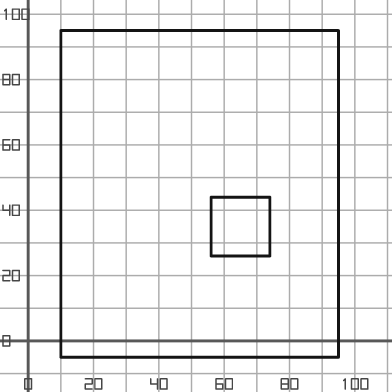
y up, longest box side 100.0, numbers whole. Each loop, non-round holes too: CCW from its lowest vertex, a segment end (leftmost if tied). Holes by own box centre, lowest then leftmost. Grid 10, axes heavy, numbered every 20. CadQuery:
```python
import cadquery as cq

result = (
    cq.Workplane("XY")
    .moveTo(10.0, -5.0)
    .lineTo(95.0, -5.0)
    .lineTo(95.0, 95.0)
    .lineTo(10.0, 95.0)
    .close()
    .moveTo(56.0, 26.0)
    .lineTo(74.0, 26.0)
    .lineTo(74.0, 44.0)
    .lineTo(56.0, 44.0)
    .close()
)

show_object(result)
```